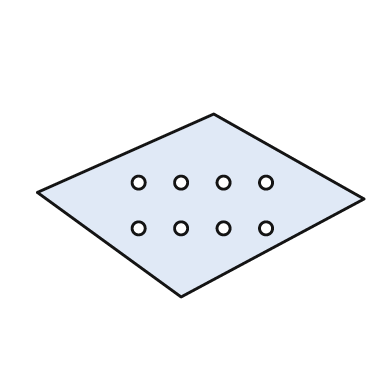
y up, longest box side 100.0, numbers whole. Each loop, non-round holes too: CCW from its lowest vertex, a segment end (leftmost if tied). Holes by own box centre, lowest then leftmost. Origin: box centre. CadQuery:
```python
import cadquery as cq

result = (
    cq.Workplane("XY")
    .moveTo(-6.0, -28.0)
    .lineTo(50.0, 2.0)
    .lineTo(4.0, 28.0)
    .lineTo(-50.0, 4.0)
    .close()
    .moveTo(-19.0, -7.0)
    .circle(2.0)
    .moveTo(-6.0, -7.0)
    .circle(2.0)
    .moveTo(7.0, -7.0)
    .circle(2.0)
    .moveTo(20.0, -7.0)
    .circle(2.0)
    .moveTo(-19.0, 7.0)
    .circle(2.0)
    .moveTo(-6.0, 7.0)
    .circle(2.0)
    .moveTo(7.0, 7.0)
    .circle(2.0)
    .moveTo(20.0, 7.0)
    .circle(2.0)
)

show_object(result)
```